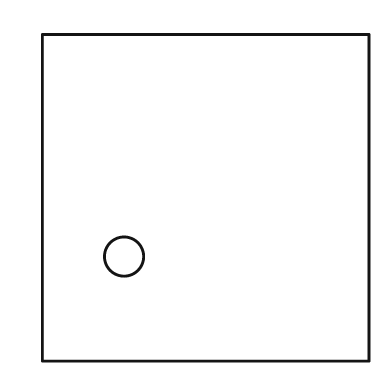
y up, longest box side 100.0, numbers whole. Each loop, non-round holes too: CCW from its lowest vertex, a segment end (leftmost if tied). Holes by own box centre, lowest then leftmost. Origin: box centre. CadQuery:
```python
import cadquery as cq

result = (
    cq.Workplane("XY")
    .moveTo(-50.0, -50.0)
    .lineTo(50.0, -50.0)
    .lineTo(50.0, 50.0)
    .lineTo(-50.0, 50.0)
    .close()
    .moveTo(-25.0, -18.0)
    .circle(6.0)
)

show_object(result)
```